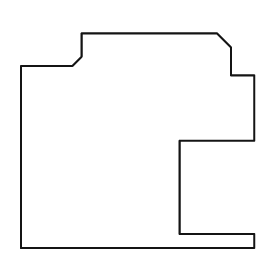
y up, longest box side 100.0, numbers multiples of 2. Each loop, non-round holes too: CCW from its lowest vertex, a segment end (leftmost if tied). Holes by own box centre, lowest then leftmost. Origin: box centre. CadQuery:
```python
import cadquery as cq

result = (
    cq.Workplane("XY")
    .moveTo(-50.0, -46.0)
    .lineTo(50.0, -46.0)
    .lineTo(50.0, -40.0)
    .lineTo(18.0, -40.0)
    .lineTo(18.0, 0.0)
    .lineTo(50.0, 0.0)
    .lineTo(50.0, 28.0)
    .lineTo(40.0, 28.0)
    .lineTo(40.0, 40.0)
    .lineTo(34.0, 46.0)
    .lineTo(-24.0, 46.0)
    .lineTo(-24.0, 36.0)
    .lineTo(-28.0, 32.0)
    .lineTo(-50.0, 32.0)
    .close()
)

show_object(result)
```